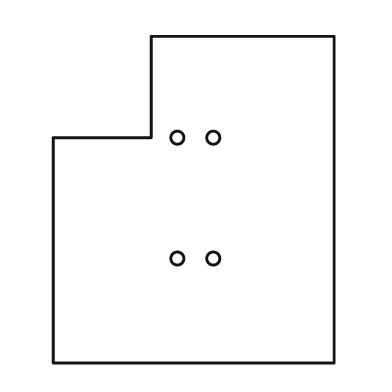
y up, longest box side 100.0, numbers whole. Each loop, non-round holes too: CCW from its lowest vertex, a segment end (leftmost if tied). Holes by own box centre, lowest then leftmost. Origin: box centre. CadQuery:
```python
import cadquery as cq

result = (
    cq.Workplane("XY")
    .moveTo(-43.0, -50.0)
    .lineTo(43.0, -50.0)
    .lineTo(43.0, 50.0)
    .lineTo(-13.0, 50.0)
    .lineTo(-13.0, 19.0)
    .lineTo(-43.0, 19.0)
    .close()
    .moveTo(-5.0, -18.0)
    .circle(2.0)
    .moveTo(6.0, -18.0)
    .circle(2.0)
    .moveTo(-5.0, 19.0)
    .circle(2.0)
    .moveTo(6.0, 19.0)
    .circle(2.0)
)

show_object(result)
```